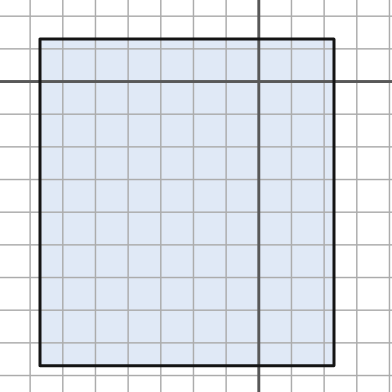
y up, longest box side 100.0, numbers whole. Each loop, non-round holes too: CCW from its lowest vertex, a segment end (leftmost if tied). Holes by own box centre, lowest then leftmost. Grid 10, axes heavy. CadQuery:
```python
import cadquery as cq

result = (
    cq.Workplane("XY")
    .moveTo(-67.0, -87.0)
    .lineTo(23.0, -87.0)
    .lineTo(23.0, 13.0)
    .lineTo(-67.0, 13.0)
    .close()
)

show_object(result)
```